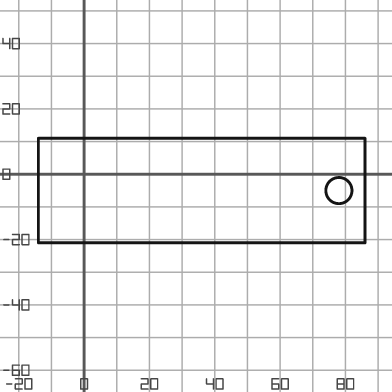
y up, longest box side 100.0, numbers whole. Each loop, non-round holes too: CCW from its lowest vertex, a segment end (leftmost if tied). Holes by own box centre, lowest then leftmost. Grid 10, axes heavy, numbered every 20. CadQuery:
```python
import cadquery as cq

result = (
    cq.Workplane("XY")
    .moveTo(-14.0, -21.0)
    .lineTo(86.0, -21.0)
    .lineTo(86.0, 11.0)
    .lineTo(-14.0, 11.0)
    .close()
    .moveTo(78.0, -5.0)
    .circle(4.0)
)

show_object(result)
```